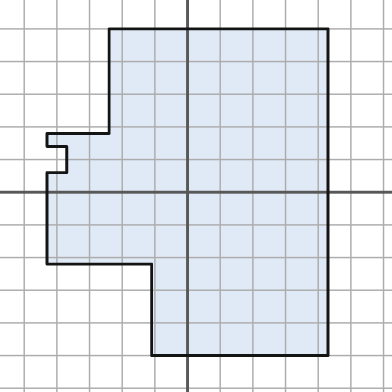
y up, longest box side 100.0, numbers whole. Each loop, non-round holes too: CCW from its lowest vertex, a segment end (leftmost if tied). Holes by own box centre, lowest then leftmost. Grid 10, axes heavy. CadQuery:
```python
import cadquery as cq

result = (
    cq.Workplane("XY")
    .moveTo(-11.0, -50.0)
    .lineTo(43.0, -50.0)
    .lineTo(43.0, 50.0)
    .lineTo(-24.0, 50.0)
    .lineTo(-24.0, 18.0)
    .lineTo(-43.0, 18.0)
    .lineTo(-43.0, 14.0)
    .lineTo(-37.0, 14.0)
    .lineTo(-37.0, 6.0)
    .lineTo(-43.0, 6.0)
    .lineTo(-43.0, -22.0)
    .lineTo(-11.0, -22.0)
    .close()
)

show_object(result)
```